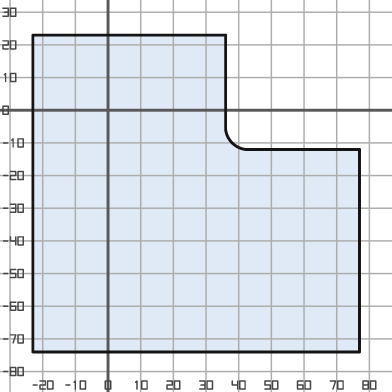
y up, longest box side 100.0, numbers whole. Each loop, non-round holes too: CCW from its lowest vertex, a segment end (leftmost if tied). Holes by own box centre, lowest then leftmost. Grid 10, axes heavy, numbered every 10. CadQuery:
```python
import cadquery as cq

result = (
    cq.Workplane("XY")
    .moveTo(-23.0, -74.0)
    .lineTo(77.0, -74.0)
    .lineTo(77.0, -12.0)
    .lineTo(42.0, -12.0)
    .threePointArc((38.0, -10.0), (36.0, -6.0))
    .lineTo(36.0, 23.0)
    .lineTo(-23.0, 23.0)
    .close()
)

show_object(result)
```